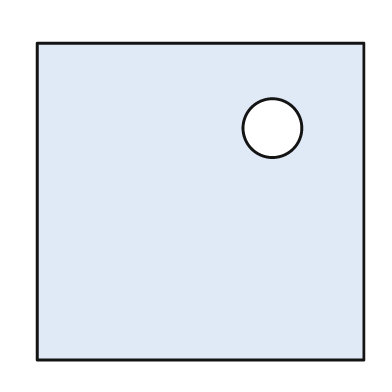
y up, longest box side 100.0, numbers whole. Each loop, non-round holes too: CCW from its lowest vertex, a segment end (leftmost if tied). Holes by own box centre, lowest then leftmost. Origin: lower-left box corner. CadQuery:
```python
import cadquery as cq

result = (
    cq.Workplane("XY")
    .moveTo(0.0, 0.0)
    .lineTo(100.0, 0.0)
    .lineTo(100.0, 97.0)
    .lineTo(0.0, 97.0)
    .close()
    .moveTo(72.0, 71.0)
    .circle(9.0)
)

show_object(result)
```